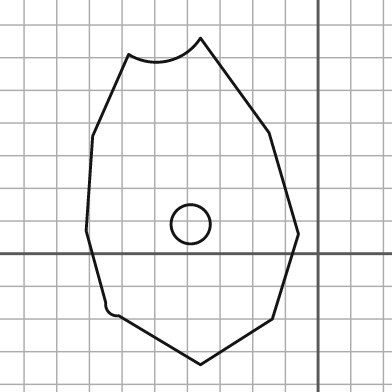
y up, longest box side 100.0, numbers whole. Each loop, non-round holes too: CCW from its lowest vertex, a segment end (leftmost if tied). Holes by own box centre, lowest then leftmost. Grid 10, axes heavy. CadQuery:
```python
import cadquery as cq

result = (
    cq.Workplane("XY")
    .moveTo(-36.0, -34.0)
    .lineTo(-14.0, -20.0)
    .lineTo(-6.0, 6.0)
    .lineTo(-15.0, 37.0)
    .lineTo(-36.0, 66.0)
    .threePointArc((-46.0, 59.0), (-58.0, 61.0))
    .lineTo(-69.0, 36.0)
    .lineTo(-71.0, 7.0)
    .lineTo(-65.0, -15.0)
    .threePointArc((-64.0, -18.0), (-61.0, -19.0))
    .close()
    .moveTo(-39.0, 9.0)
    .circle(6.0)
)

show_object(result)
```